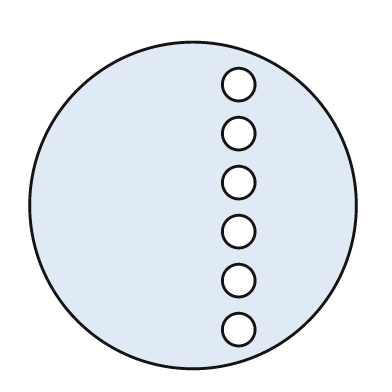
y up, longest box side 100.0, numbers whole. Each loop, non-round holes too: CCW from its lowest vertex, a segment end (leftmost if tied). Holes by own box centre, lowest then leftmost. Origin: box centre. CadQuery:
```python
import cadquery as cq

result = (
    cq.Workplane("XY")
    .moveTo(0.0, 0.0)
    .circle(50.0)
    .moveTo(14.0, -38.0)
    .circle(5.0)
    .moveTo(14.0, -23.0)
    .circle(5.0)
    .moveTo(14.0, -8.0)
    .circle(5.0)
    .moveTo(14.0, 7.0)
    .circle(5.0)
    .moveTo(14.0, 22.0)
    .circle(5.0)
    .moveTo(14.0, 37.0)
    .circle(5.0)
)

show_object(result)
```